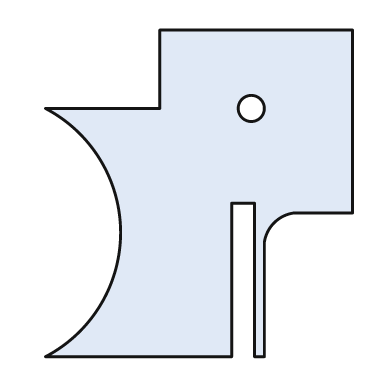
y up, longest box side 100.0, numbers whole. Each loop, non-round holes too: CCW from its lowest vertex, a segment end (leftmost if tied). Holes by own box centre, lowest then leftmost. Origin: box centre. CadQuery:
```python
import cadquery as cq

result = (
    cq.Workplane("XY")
    .moveTo(-47.0, -50.0)
    .lineTo(10.0, -50.0)
    .lineTo(10.0, -3.0)
    .lineTo(17.0, -3.0)
    .lineTo(17.0, -50.0)
    .lineTo(20.0, -50.0)
    .lineTo(20.0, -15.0)
    .threePointArc((23.0, -9.0), (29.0, -6.0))
    .lineTo(47.0, -6.0)
    .lineTo(47.0, 50.0)
    .lineTo(-12.0, 50.0)
    .lineTo(-12.0, 26.0)
    .lineTo(-47.0, 26.0)
    .threePointArc((-24.0, -12.0), (-47.0, -50.0))
    .close()
    .moveTo(16.0, 26.0)
    .circle(4.0)
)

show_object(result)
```